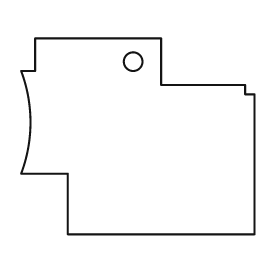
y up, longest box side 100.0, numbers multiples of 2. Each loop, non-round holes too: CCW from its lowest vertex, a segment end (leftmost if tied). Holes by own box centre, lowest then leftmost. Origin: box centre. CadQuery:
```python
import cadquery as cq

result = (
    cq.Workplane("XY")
    .moveTo(-30.0, -42.0)
    .lineTo(50.0, -42.0)
    .lineTo(50.0, 18.0)
    .lineTo(46.0, 18.0)
    .lineTo(46.0, 22.0)
    .lineTo(10.0, 22.0)
    .lineTo(10.0, 42.0)
    .lineTo(-44.0, 42.0)
    .lineTo(-44.0, 28.0)
    .lineTo(-50.0, 28.0)
    .threePointArc((-46.0, 6.0), (-50.0, -16.0))
    .lineTo(-30.0, -16.0)
    .close()
    .moveTo(-2.0, 32.0)
    .circle(4.0)
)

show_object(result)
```